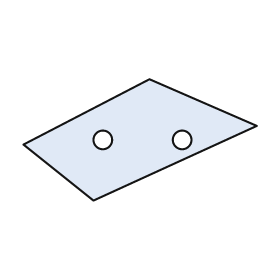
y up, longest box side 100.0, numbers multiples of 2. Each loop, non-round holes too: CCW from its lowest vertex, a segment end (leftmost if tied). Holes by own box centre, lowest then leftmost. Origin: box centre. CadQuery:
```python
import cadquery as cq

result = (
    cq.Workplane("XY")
    .moveTo(-20.0, -26.0)
    .lineTo(50.0, 6.0)
    .lineTo(4.0, 26.0)
    .lineTo(-50.0, -2.0)
    .close()
    .moveTo(-16.0, 0.0)
    .circle(4.0)
    .moveTo(18.0, 0.0)
    .circle(4.0)
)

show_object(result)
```